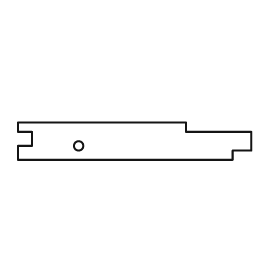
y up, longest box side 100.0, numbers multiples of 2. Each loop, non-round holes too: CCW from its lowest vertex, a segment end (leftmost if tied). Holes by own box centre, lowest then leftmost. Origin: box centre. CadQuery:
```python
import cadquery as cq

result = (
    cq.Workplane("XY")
    .moveTo(-50.0, -8.0)
    .lineTo(42.0, -8.0)
    .lineTo(42.0, -4.0)
    .lineTo(50.0, -4.0)
    .lineTo(50.0, 4.0)
    .lineTo(22.0, 4.0)
    .lineTo(22.0, 8.0)
    .lineTo(-50.0, 8.0)
    .lineTo(-50.0, 4.0)
    .lineTo(-44.0, 4.0)
    .lineTo(-44.0, -2.0)
    .lineTo(-50.0, -2.0)
    .close()
    .moveTo(-24.0, -2.0)
    .circle(2.0)
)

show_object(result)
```